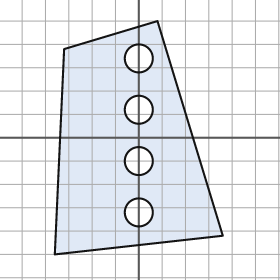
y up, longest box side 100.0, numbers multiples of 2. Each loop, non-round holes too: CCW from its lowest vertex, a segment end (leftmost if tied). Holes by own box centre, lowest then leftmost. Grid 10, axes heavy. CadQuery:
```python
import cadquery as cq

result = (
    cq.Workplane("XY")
    .moveTo(-36.0, -50.0)
    .lineTo(36.0, -42.0)
    .lineTo(8.0, 50.0)
    .lineTo(-32.0, 38.0)
    .close()
    .moveTo(0.0, -32.0)
    .circle(6.0)
    .moveTo(0.0, -10.0)
    .circle(6.0)
    .moveTo(0.0, 12.0)
    .circle(6.0)
    .moveTo(0.0, 34.0)
    .circle(6.0)
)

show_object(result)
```